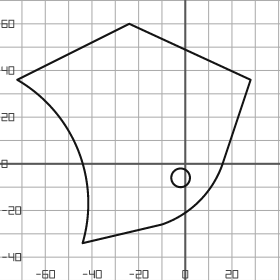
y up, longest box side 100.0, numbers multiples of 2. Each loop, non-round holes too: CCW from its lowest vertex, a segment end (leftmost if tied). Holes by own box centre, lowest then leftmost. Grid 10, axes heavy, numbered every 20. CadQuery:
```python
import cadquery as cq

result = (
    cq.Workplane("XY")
    .moveTo(-44.0, -34.0)
    .lineTo(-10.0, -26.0)
    .threePointArc((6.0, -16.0), (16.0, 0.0))
    .lineTo(28.0, 36.0)
    .lineTo(-24.0, 60.0)
    .lineTo(-72.0, 36.0)
    .threePointArc((-46.0, 6.0), (-44.0, -34.0))
    .close()
    .moveTo(-2.0, -6.0)
    .circle(4.0)
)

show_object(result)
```